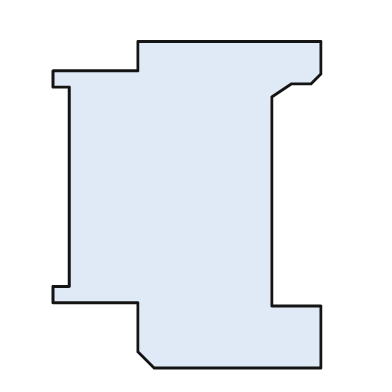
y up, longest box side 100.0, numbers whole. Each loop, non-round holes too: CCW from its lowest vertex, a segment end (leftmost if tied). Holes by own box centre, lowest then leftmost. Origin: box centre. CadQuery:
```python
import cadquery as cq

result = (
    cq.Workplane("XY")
    .moveTo(-10.0, -50.0)
    .lineTo(41.0, -50.0)
    .lineTo(41.0, -31.0)
    .lineTo(26.0, -31.0)
    .lineTo(26.0, 33.0)
    .lineTo(32.0, 37.0)
    .lineTo(38.0, 37.0)
    .lineTo(41.0, 40.0)
    .lineTo(41.0, 50.0)
    .lineTo(-15.0, 50.0)
    .lineTo(-15.0, 41.0)
    .lineTo(-41.0, 41.0)
    .lineTo(-41.0, 36.0)
    .lineTo(-36.0, 36.0)
    .lineTo(-36.0, -25.0)
    .lineTo(-41.0, -25.0)
    .lineTo(-41.0, -30.0)
    .lineTo(-15.0, -30.0)
    .lineTo(-15.0, -45.0)
    .close()
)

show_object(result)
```